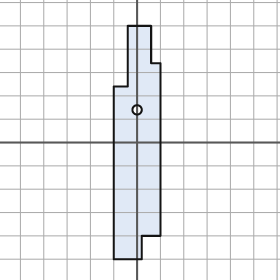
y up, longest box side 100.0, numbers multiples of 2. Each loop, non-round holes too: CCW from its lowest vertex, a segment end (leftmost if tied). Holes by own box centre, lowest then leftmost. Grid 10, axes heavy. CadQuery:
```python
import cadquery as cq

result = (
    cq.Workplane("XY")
    .moveTo(-10.0, -50.0)
    .lineTo(2.0, -50.0)
    .lineTo(2.0, -40.0)
    .lineTo(10.0, -40.0)
    .lineTo(10.0, 34.0)
    .lineTo(6.0, 34.0)
    .lineTo(6.0, 50.0)
    .lineTo(-4.0, 50.0)
    .lineTo(-4.0, 24.0)
    .lineTo(-10.0, 24.0)
    .close()
    .moveTo(0.0, 14.0)
    .circle(2.0)
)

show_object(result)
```